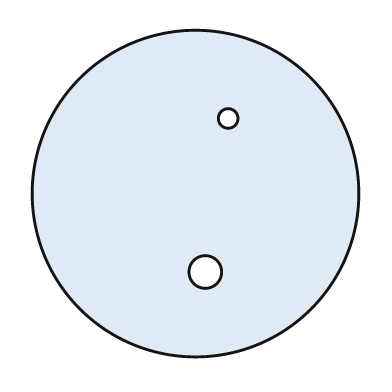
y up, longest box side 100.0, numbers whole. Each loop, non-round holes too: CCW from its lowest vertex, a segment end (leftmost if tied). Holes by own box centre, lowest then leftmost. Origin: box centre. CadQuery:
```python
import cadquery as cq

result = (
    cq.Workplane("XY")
    .moveTo(0.0, 0.0)
    .circle(50.0)
    .moveTo(3.0, -24.0)
    .circle(5.0)
    .moveTo(10.0, 23.0)
    .circle(3.0)
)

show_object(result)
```